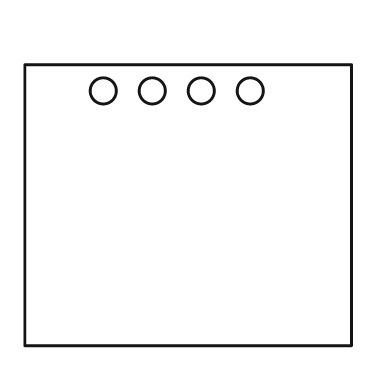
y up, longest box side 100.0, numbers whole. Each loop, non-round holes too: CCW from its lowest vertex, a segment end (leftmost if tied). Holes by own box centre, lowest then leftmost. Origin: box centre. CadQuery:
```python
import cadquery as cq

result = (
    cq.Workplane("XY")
    .moveTo(-50.0, -43.0)
    .lineTo(50.0, -43.0)
    .lineTo(50.0, 43.0)
    .lineTo(-50.0, 43.0)
    .close()
    .moveTo(-26.0, 35.0)
    .circle(4.0)
    .moveTo(-11.0, 35.0)
    .circle(4.0)
    .moveTo(4.0, 35.0)
    .circle(4.0)
    .moveTo(19.0, 35.0)
    .circle(4.0)
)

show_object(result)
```